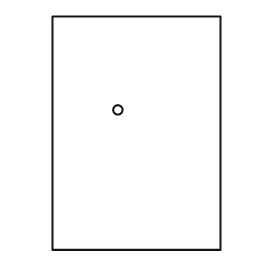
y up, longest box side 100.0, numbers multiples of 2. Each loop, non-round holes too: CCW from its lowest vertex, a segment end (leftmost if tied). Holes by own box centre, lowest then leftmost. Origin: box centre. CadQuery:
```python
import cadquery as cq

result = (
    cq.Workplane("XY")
    .moveTo(-36.0, -50.0)
    .lineTo(36.0, -50.0)
    .lineTo(36.0, 50.0)
    .lineTo(-36.0, 50.0)
    .close()
    .moveTo(-8.0, 10.0)
    .circle(2.0)
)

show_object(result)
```